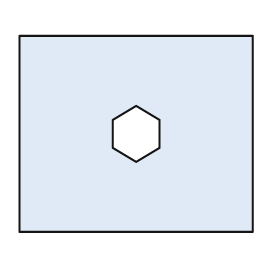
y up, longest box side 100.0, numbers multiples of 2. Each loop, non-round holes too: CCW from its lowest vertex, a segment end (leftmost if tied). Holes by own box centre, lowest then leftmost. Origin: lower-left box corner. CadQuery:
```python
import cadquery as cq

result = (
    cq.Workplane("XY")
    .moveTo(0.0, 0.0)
    .lineTo(100.0, 0.0)
    .lineTo(100.0, 84.0)
    .lineTo(0.0, 84.0)
    .close()
    .moveTo(50.0, 30.0)
    .lineTo(60.0, 36.0)
    .lineTo(60.0, 48.0)
    .lineTo(50.0, 54.0)
    .lineTo(40.0, 48.0)
    .lineTo(40.0, 36.0)
    .close()
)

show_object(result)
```